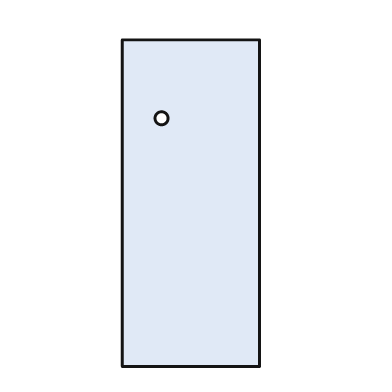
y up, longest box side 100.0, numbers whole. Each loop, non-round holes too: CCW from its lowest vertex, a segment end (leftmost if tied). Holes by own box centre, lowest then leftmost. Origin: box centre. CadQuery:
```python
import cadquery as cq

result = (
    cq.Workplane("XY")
    .moveTo(-21.0, -50.0)
    .lineTo(21.0, -50.0)
    .lineTo(21.0, 50.0)
    .lineTo(-21.0, 50.0)
    .close()
    .moveTo(-9.0, 26.0)
    .circle(2.0)
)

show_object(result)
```